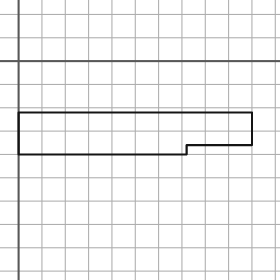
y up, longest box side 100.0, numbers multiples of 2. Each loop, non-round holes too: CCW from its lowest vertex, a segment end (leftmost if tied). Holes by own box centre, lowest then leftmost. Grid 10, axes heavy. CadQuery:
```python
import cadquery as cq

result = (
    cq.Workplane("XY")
    .moveTo(0.0, -40.0)
    .lineTo(72.0, -40.0)
    .lineTo(72.0, -36.0)
    .lineTo(100.0, -36.0)
    .lineTo(100.0, -22.0)
    .lineTo(0.0, -22.0)
    .close()
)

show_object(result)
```